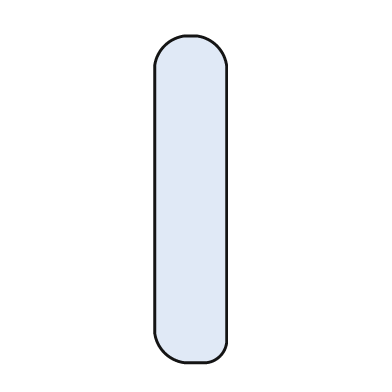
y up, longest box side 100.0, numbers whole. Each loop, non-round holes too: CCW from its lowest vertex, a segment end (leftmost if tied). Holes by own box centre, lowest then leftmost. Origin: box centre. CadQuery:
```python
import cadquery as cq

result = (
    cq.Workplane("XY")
    .moveTo(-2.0, -50.0)
    .lineTo(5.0, -50.0)
    .threePointArc((9.0, -48.0), (11.0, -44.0))
    .lineTo(11.0, 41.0)
    .threePointArc((8.0, 47.0), (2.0, 50.0))
    .lineTo(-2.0, 50.0)
    .threePointArc((-8.0, 47.0), (-11.0, 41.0))
    .lineTo(-11.0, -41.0)
    .threePointArc((-8.0, -47.0), (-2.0, -50.0))
    .close()
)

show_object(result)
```